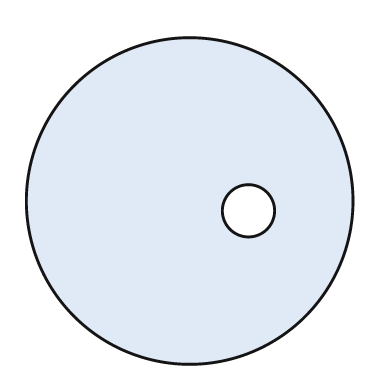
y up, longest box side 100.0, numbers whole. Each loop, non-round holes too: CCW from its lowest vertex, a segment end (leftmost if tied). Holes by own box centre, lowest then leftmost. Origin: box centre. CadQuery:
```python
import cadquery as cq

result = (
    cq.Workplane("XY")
    .moveTo(0.0, 0.0)
    .circle(50.0)
    .moveTo(18.0, -3.0)
    .circle(8.0)
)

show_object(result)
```